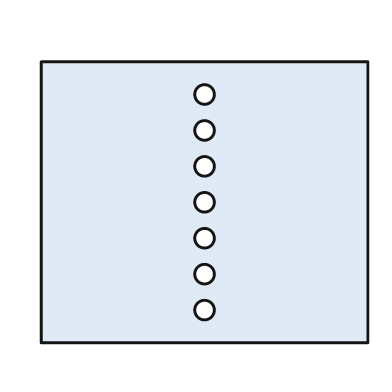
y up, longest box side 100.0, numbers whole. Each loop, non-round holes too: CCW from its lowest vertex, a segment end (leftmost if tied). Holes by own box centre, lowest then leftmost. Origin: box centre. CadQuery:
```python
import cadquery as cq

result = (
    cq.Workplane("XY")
    .moveTo(-50.0, -43.0)
    .lineTo(50.0, -43.0)
    .lineTo(50.0, 43.0)
    .lineTo(-50.0, 43.0)
    .close()
    .moveTo(0.0, -33.0)
    .circle(3.0)
    .moveTo(0.0, -22.0)
    .circle(3.0)
    .moveTo(0.0, -11.0)
    .circle(3.0)
    .moveTo(0.0, 0.0)
    .circle(3.0)
    .moveTo(0.0, 11.0)
    .circle(3.0)
    .moveTo(0.0, 22.0)
    .circle(3.0)
    .moveTo(0.0, 33.0)
    .circle(3.0)
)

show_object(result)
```